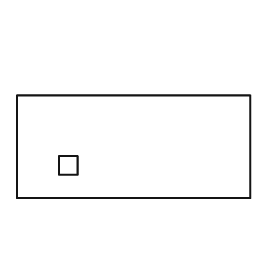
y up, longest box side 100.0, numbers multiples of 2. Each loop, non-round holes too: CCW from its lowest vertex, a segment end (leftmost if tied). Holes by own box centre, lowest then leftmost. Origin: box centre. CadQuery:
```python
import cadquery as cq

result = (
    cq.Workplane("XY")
    .moveTo(-50.0, -22.0)
    .lineTo(50.0, -22.0)
    .lineTo(50.0, 22.0)
    .lineTo(-50.0, 22.0)
    .close()
    .moveTo(-32.0, -12.0)
    .lineTo(-24.0, -12.0)
    .lineTo(-24.0, -4.0)
    .lineTo(-32.0, -4.0)
    .close()
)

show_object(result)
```